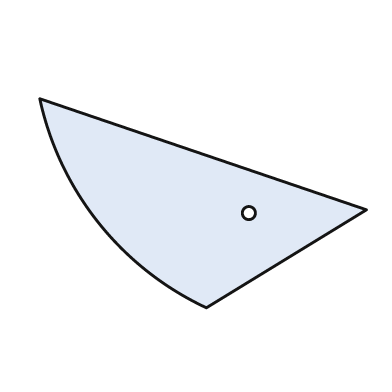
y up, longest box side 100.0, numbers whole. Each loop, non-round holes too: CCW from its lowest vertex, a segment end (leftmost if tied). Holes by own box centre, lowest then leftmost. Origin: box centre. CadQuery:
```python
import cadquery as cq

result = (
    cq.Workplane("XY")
    .moveTo(1.0, -32.0)
    .lineTo(50.0, -2.0)
    .lineTo(-50.0, 32.0)
    .threePointArc((-32.0, -6.0), (1.0, -32.0))
    .close()
    .moveTo(14.0, -3.0)
    .circle(2.0)
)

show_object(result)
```